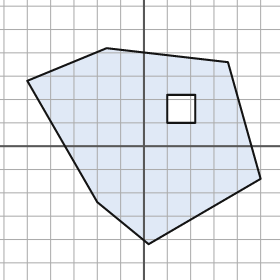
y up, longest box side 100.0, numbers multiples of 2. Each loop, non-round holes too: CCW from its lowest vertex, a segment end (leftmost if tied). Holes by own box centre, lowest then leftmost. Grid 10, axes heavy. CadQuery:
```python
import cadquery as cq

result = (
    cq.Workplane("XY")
    .moveTo(2.0, -42.0)
    .lineTo(50.0, -14.0)
    .lineTo(36.0, 36.0)
    .lineTo(-16.0, 42.0)
    .lineTo(-50.0, 28.0)
    .lineTo(-20.0, -24.0)
    .close()
    .moveTo(10.0, 10.0)
    .lineTo(22.0, 10.0)
    .lineTo(22.0, 22.0)
    .lineTo(10.0, 22.0)
    .close()
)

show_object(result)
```